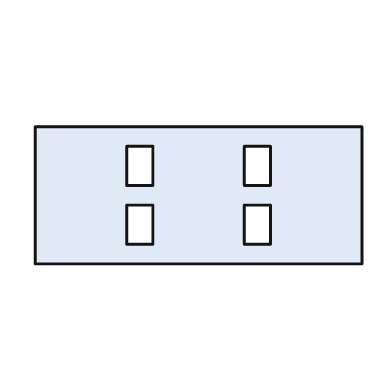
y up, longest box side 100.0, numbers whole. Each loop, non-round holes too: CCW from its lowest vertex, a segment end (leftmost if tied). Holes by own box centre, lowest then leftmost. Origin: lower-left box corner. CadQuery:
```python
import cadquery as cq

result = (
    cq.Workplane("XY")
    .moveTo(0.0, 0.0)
    .lineTo(100.0, 0.0)
    .lineTo(100.0, 42.0)
    .lineTo(0.0, 42.0)
    .close()
    .moveTo(28.0, 6.0)
    .lineTo(36.0, 6.0)
    .lineTo(36.0, 18.0)
    .lineTo(28.0, 18.0)
    .close()
    .moveTo(64.0, 6.0)
    .lineTo(72.0, 6.0)
    .lineTo(72.0, 18.0)
    .lineTo(64.0, 18.0)
    .close()
    .moveTo(28.0, 24.0)
    .lineTo(36.0, 24.0)
    .lineTo(36.0, 36.0)
    .lineTo(28.0, 36.0)
    .close()
    .moveTo(64.0, 24.0)
    .lineTo(72.0, 24.0)
    .lineTo(72.0, 36.0)
    .lineTo(64.0, 36.0)
    .close()
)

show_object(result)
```